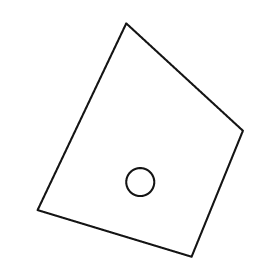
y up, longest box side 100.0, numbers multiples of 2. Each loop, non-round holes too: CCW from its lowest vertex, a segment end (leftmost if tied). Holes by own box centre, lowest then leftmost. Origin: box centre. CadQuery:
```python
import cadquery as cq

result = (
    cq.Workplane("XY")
    .moveTo(22.0, -50.0)
    .lineTo(44.0, 4.0)
    .lineTo(-6.0, 50.0)
    .lineTo(-44.0, -30.0)
    .close()
    .moveTo(0.0, -18.0)
    .circle(6.0)
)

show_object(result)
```